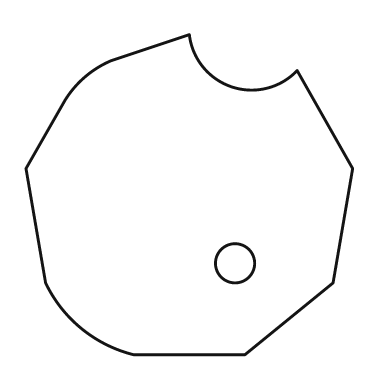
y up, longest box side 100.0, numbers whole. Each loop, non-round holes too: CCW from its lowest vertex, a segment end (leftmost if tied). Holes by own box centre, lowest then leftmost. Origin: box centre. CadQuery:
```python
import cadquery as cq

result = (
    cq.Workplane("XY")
    .moveTo(-17.0, -49.0)
    .lineTo(17.0, -49.0)
    .lineTo(44.0, -27.0)
    .lineTo(50.0, 8.0)
    .lineTo(33.0, 38.0)
    .threePointArc((13.0, 33.0), (0.0, 49.0))
    .lineTo(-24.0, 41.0)
    .threePointArc((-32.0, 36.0), (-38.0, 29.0))
    .lineTo(-50.0, 8.0)
    .lineTo(-44.0, -27.0)
    .threePointArc((-33.0, -41.0), (-17.0, -49.0))
    .close()
    .moveTo(14.0, -21.0)
    .circle(6.0)
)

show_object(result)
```